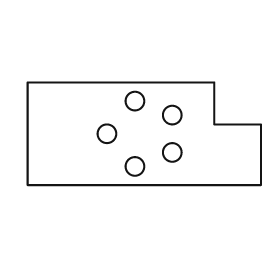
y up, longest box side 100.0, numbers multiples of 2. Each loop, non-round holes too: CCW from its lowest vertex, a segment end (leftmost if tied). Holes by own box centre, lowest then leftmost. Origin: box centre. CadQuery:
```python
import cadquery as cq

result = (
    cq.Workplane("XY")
    .moveTo(-50.0, -22.0)
    .lineTo(50.0, -22.0)
    .lineTo(50.0, 4.0)
    .lineTo(30.0, 4.0)
    .lineTo(30.0, 22.0)
    .lineTo(-50.0, 22.0)
    .close()
    .moveTo(-4.0, -14.0)
    .circle(4.0)
    .moveTo(12.0, -8.0)
    .circle(4.0)
    .moveTo(-16.0, 0.0)
    .circle(4.0)
    .moveTo(12.0, 8.0)
    .circle(4.0)
    .moveTo(-4.0, 14.0)
    .circle(4.0)
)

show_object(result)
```